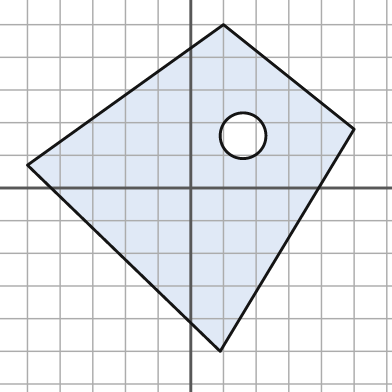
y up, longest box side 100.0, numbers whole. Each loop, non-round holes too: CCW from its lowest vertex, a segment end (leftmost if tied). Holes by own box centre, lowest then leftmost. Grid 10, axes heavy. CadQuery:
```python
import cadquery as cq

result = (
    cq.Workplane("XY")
    .moveTo(9.0, -50.0)
    .lineTo(50.0, 18.0)
    .lineTo(10.0, 50.0)
    .lineTo(-50.0, 7.0)
    .close()
    .moveTo(16.0, 16.0)
    .circle(7.0)
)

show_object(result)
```